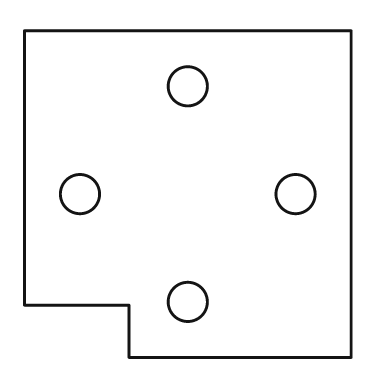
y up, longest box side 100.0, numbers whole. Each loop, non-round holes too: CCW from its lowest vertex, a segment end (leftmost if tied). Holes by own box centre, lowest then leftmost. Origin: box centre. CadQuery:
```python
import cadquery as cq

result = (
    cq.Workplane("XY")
    .moveTo(-18.0, -50.0)
    .lineTo(50.0, -50.0)
    .lineTo(50.0, 50.0)
    .lineTo(-50.0, 50.0)
    .lineTo(-50.0, -34.0)
    .lineTo(-18.0, -34.0)
    .close()
    .moveTo(0.0, -33.0)
    .circle(6.0)
    .moveTo(-33.0, 0.0)
    .circle(6.0)
    .moveTo(33.0, 0.0)
    .circle(6.0)
    .moveTo(0.0, 33.0)
    .circle(6.0)
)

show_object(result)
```